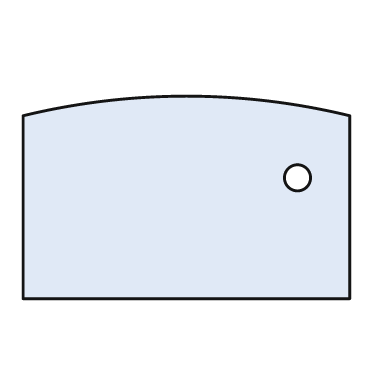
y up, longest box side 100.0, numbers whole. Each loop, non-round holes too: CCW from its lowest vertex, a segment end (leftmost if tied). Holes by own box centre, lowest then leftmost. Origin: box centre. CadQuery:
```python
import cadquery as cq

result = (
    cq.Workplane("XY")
    .moveTo(-50.0, -31.0)
    .lineTo(50.0, -31.0)
    .lineTo(50.0, 25.0)
    .threePointArc((0.0, 31.0), (-50.0, 25.0))
    .close()
    .moveTo(34.0, 6.0)
    .circle(4.0)
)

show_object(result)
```